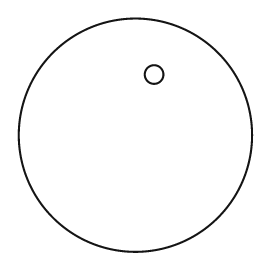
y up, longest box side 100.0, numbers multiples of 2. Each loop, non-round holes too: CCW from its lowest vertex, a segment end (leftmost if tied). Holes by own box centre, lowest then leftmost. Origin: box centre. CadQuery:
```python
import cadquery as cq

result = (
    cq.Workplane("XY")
    .moveTo(0.0, 0.0)
    .circle(50.0)
    .moveTo(8.0, 26.0)
    .circle(4.0)
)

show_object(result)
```